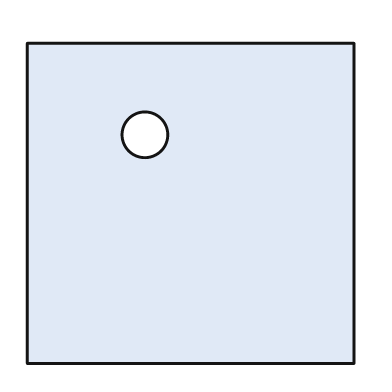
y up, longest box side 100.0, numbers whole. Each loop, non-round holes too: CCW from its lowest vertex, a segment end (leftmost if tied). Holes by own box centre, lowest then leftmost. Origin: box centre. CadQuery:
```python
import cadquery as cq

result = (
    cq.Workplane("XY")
    .moveTo(-50.0, -49.0)
    .lineTo(50.0, -49.0)
    .lineTo(50.0, 49.0)
    .lineTo(-50.0, 49.0)
    .close()
    .moveTo(-14.0, 21.0)
    .circle(7.0)
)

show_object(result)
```